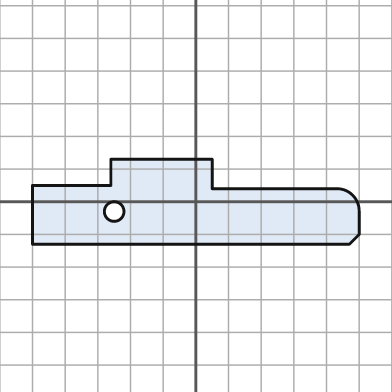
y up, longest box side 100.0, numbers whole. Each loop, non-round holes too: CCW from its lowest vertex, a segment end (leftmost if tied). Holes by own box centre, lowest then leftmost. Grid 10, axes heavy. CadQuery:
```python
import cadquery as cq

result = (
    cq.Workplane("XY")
    .moveTo(-50.0, -13.0)
    .lineTo(47.0, -13.0)
    .lineTo(50.0, -10.0)
    .lineTo(50.0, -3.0)
    .threePointArc((48.0, 2.0), (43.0, 4.0))
    .lineTo(5.0, 4.0)
    .lineTo(5.0, 13.0)
    .lineTo(-26.0, 13.0)
    .lineTo(-26.0, 5.0)
    .lineTo(-50.0, 5.0)
    .close()
    .moveTo(-25.0, -3.0)
    .circle(3.0)
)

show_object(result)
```